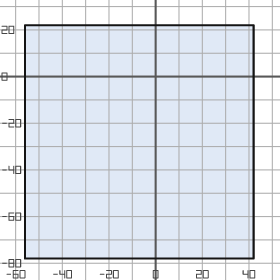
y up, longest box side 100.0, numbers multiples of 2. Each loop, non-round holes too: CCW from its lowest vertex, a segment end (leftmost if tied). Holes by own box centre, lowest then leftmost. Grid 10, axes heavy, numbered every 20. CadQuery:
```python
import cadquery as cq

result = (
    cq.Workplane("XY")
    .moveTo(-56.0, -78.0)
    .lineTo(42.0, -78.0)
    .lineTo(42.0, 22.0)
    .lineTo(-56.0, 22.0)
    .close()
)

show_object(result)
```